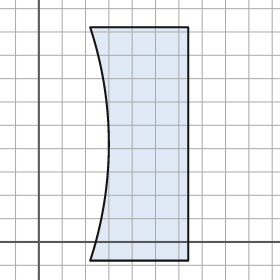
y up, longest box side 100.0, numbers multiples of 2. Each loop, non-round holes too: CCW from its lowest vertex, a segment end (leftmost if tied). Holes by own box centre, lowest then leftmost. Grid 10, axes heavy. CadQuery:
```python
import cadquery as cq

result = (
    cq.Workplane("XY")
    .moveTo(22.0, -8.0)
    .lineTo(64.0, -8.0)
    .lineTo(64.0, 92.0)
    .lineTo(22.0, 92.0)
    .threePointArc((30.0, 42.0), (22.0, -8.0))
    .close()
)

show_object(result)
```